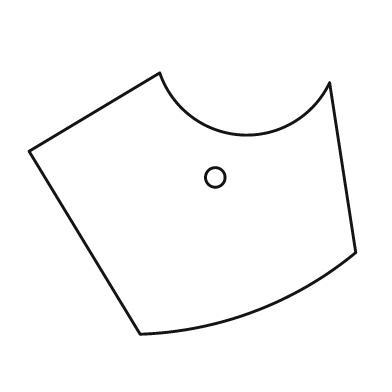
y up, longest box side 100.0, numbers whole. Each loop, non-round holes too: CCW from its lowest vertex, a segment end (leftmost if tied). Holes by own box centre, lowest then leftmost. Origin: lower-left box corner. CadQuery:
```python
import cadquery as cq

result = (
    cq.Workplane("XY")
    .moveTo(34.0, 0.0)
    .threePointArc((69.0, 7.0), (100.0, 25.0))
    .lineTo(92.0, 77.0)
    .threePointArc((65.0, 61.0), (40.0, 80.0))
    .lineTo(0.0, 56.0)
    .close()
    .moveTo(57.0, 48.0)
    .circle(3.0)
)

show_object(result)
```